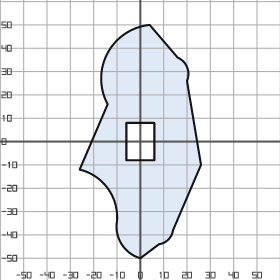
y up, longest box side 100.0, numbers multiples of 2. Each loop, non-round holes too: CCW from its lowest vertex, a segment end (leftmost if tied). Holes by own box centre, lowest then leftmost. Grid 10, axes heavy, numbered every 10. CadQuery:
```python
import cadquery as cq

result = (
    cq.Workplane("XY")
    .moveTo(0.0, -50.0)
    .lineTo(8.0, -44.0)
    .threePointArc((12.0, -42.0), (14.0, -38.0))
    .lineTo(26.0, -10.0)
    .lineTo(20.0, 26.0)
    .threePointArc((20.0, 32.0), (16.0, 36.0))
    .lineTo(4.0, 50.0)
    .threePointArc((-14.0, 38.0), (-14.0, 16.0))
    .lineTo(-26.0, -12.0)
    .threePointArc((-14.0, -20.0), (-10.0, -34.0))
    .threePointArc((-8.0, -44.0), (0.0, -50.0))
    .close()
    .moveTo(-6.0, -8.0)
    .lineTo(6.0, -8.0)
    .lineTo(6.0, 8.0)
    .lineTo(-6.0, 8.0)
    .close()
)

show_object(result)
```